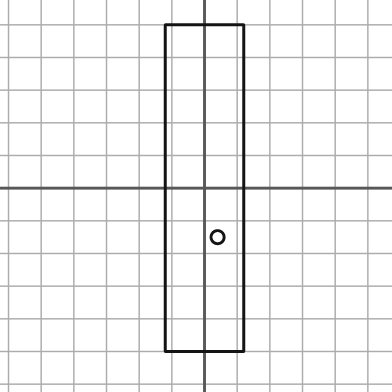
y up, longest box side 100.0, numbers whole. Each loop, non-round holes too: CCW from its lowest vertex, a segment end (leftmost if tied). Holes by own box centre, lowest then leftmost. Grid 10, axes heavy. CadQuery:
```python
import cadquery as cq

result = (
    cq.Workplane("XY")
    .moveTo(-12.0, -50.0)
    .lineTo(12.0, -50.0)
    .lineTo(12.0, 50.0)
    .lineTo(-12.0, 50.0)
    .close()
    .moveTo(4.0, -15.0)
    .circle(2.0)
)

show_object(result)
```